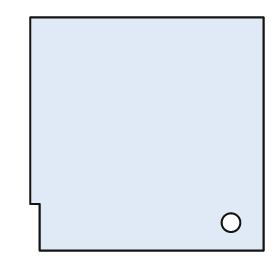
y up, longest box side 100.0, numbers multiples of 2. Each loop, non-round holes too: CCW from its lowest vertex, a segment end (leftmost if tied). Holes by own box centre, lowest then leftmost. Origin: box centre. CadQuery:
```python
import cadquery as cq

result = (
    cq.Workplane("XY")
    .moveTo(-46.0, -50.0)
    .lineTo(50.0, -50.0)
    .lineTo(50.0, 50.0)
    .lineTo(-50.0, 50.0)
    .lineTo(-50.0, -30.0)
    .lineTo(-46.0, -30.0)
    .close()
    .moveTo(36.0, -38.0)
    .circle(4.0)
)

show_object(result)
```